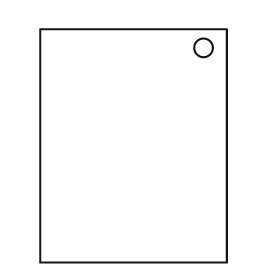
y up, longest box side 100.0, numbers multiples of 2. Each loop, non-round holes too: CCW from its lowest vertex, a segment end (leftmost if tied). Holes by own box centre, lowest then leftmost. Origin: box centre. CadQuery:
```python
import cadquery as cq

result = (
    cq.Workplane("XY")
    .moveTo(-40.0, -50.0)
    .lineTo(40.0, -50.0)
    .lineTo(40.0, 50.0)
    .lineTo(-40.0, 50.0)
    .close()
    .moveTo(30.0, 42.0)
    .circle(4.0)
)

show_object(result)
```